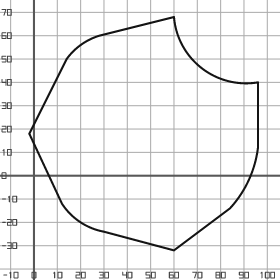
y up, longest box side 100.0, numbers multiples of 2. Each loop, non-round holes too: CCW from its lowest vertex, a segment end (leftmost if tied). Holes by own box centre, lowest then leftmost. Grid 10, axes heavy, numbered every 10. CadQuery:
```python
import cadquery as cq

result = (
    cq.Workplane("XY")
    .moveTo(60.0, -32.0)
    .lineTo(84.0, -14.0)
    .threePointArc((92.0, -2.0), (96.0, 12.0))
    .lineTo(96.0, 40.0)
    .threePointArc((72.0, 46.0), (60.0, 68.0))
    .lineTo(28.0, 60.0)
    .threePointArc((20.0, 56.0), (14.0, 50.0))
    .lineTo(-2.0, 18.0)
    .lineTo(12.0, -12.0)
    .threePointArc((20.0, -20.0), (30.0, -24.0))
    .close()
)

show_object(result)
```